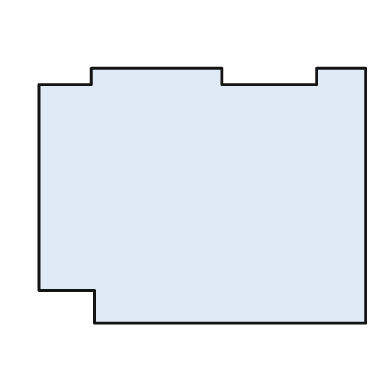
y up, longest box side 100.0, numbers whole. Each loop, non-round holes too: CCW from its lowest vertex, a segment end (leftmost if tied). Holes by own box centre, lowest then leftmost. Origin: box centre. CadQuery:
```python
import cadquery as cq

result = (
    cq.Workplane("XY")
    .moveTo(-33.0, -39.0)
    .lineTo(50.0, -39.0)
    .lineTo(50.0, 39.0)
    .lineTo(35.0, 39.0)
    .lineTo(35.0, 34.0)
    .lineTo(6.0, 34.0)
    .lineTo(6.0, 39.0)
    .lineTo(-34.0, 39.0)
    .lineTo(-34.0, 34.0)
    .lineTo(-50.0, 34.0)
    .lineTo(-50.0, -29.0)
    .lineTo(-33.0, -29.0)
    .close()
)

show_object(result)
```